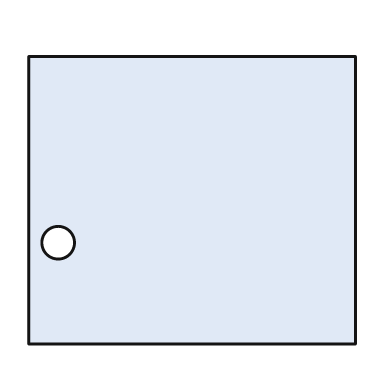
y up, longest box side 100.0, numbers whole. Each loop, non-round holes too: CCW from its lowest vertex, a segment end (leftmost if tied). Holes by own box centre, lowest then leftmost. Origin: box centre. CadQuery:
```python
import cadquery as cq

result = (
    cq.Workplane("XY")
    .moveTo(-50.0, -44.0)
    .lineTo(50.0, -44.0)
    .lineTo(50.0, 44.0)
    .lineTo(-50.0, 44.0)
    .close()
    .moveTo(-41.0, -13.0)
    .circle(5.0)
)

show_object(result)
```